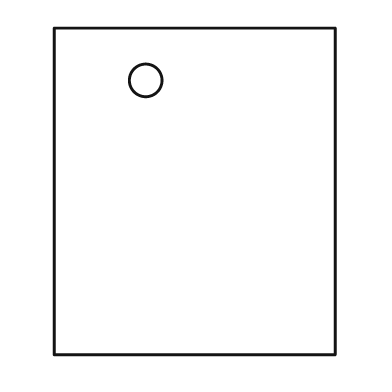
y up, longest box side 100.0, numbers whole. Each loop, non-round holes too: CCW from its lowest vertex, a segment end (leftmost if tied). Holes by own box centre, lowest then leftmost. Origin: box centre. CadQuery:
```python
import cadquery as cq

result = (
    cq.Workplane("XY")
    .moveTo(-43.0, -50.0)
    .lineTo(43.0, -50.0)
    .lineTo(43.0, 50.0)
    .lineTo(-43.0, 50.0)
    .close()
    .moveTo(-15.0, 34.0)
    .circle(5.0)
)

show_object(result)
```